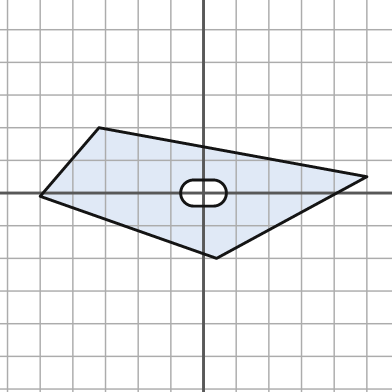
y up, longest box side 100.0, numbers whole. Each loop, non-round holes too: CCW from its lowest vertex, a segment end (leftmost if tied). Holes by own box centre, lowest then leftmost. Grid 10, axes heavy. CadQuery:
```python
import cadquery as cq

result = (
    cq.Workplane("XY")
    .moveTo(4.0, -20.0)
    .lineTo(50.0, 5.0)
    .lineTo(-32.0, 20.0)
    .lineTo(-50.0, -1.0)
    .close()
    .moveTo(-3.0, -4.0)
    .lineTo(3.0, -4.0)
    .threePointArc((7.0, 0.0), (3.0, 4.0))
    .lineTo(-3.0, 4.0)
    .threePointArc((-7.0, 0.0), (-3.0, -4.0))
    .close()
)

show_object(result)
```